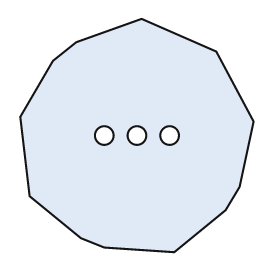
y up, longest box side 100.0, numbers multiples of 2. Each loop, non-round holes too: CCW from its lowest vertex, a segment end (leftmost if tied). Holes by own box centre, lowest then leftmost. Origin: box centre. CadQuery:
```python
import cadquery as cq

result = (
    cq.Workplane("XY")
    .moveTo(16.0, -50.0)
    .lineTo(38.0, -32.0)
    .lineTo(44.0, -22.0)
    .lineTo(50.0, 6.0)
    .lineTo(34.0, 36.0)
    .lineTo(2.0, 50.0)
    .lineTo(-26.0, 40.0)
    .lineTo(-36.0, 32.0)
    .lineTo(-50.0, 8.0)
    .lineTo(-46.0, -26.0)
    .lineTo(-24.0, -44.0)
    .lineTo(-14.0, -48.0)
    .close()
    .moveTo(-14.0, 0.0)
    .circle(4.0)
    .moveTo(0.0, 0.0)
    .circle(4.0)
    .moveTo(14.0, 0.0)
    .circle(4.0)
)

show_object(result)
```